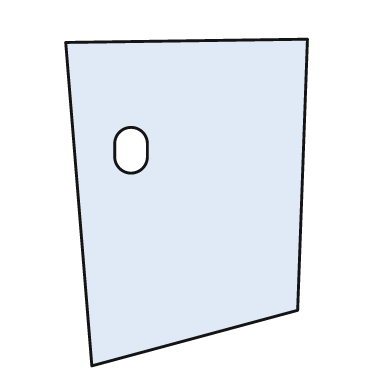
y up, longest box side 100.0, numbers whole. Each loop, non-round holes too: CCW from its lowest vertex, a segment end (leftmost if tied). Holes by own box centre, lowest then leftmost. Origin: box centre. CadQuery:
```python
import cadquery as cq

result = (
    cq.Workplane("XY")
    .moveTo(-29.0, -50.0)
    .lineTo(34.0, -33.0)
    .lineTo(37.0, 50.0)
    .lineTo(-37.0, 49.0)
    .close()
    .moveTo(-22.0, 14.0)
    .threePointArc((-17.0, 9.0), (-12.0, 14.0))
    .lineTo(-12.0, 18.0)
    .threePointArc((-17.0, 23.0), (-22.0, 18.0))
    .close()
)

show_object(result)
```